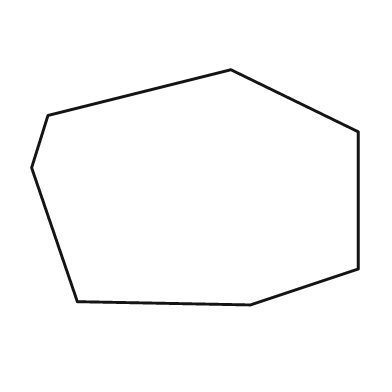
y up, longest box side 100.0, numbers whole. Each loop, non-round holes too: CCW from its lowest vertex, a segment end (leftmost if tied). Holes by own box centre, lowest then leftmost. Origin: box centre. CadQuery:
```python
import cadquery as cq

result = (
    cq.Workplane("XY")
    .moveTo(17.0, -36.0)
    .lineTo(50.0, -25.0)
    .lineTo(50.0, 17.0)
    .lineTo(11.0, 36.0)
    .lineTo(-45.0, 22.0)
    .lineTo(-50.0, 6.0)
    .lineTo(-36.0, -35.0)
    .close()
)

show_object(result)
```